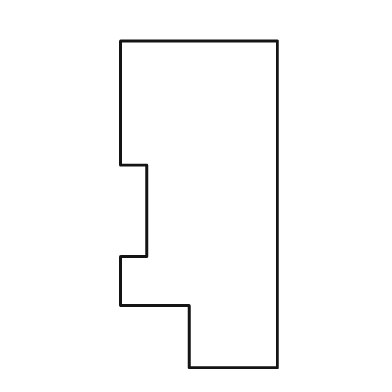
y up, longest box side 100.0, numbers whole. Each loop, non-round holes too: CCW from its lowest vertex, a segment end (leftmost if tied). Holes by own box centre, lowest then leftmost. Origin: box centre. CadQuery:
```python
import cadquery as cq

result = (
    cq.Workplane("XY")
    .moveTo(-3.0, -50.0)
    .lineTo(24.0, -50.0)
    .lineTo(24.0, 50.0)
    .lineTo(-24.0, 50.0)
    .lineTo(-24.0, 12.0)
    .lineTo(-16.0, 12.0)
    .lineTo(-16.0, -16.0)
    .lineTo(-24.0, -16.0)
    .lineTo(-24.0, -31.0)
    .lineTo(-3.0, -31.0)
    .close()
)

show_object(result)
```